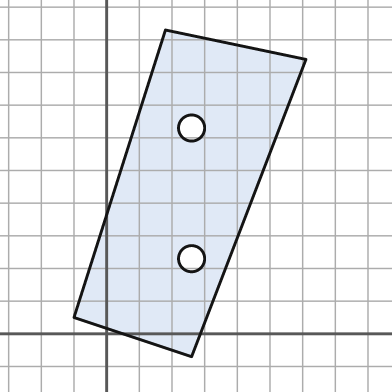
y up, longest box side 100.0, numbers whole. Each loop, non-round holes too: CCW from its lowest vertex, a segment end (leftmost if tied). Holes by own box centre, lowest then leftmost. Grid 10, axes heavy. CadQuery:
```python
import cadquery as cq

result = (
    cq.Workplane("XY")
    .moveTo(26.0, -7.0)
    .lineTo(61.0, 84.0)
    .lineTo(18.0, 93.0)
    .lineTo(-10.0, 5.0)
    .close()
    .moveTo(26.0, 23.0)
    .circle(4.0)
    .moveTo(26.0, 63.0)
    .circle(4.0)
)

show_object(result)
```